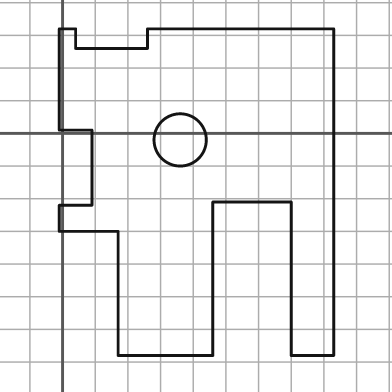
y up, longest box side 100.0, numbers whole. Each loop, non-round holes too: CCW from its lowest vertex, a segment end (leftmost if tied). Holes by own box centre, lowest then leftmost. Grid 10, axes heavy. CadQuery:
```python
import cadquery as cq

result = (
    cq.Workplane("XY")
    .moveTo(17.0, -68.0)
    .lineTo(46.0, -68.0)
    .lineTo(46.0, -21.0)
    .lineTo(70.0, -21.0)
    .lineTo(70.0, -68.0)
    .lineTo(83.0, -68.0)
    .lineTo(83.0, 32.0)
    .lineTo(26.0, 32.0)
    .lineTo(26.0, 26.0)
    .lineTo(4.0, 26.0)
    .lineTo(4.0, 32.0)
    .lineTo(-1.0, 32.0)
    .lineTo(-1.0, 1.0)
    .lineTo(9.0, 1.0)
    .lineTo(9.0, -22.0)
    .lineTo(-1.0, -22.0)
    .lineTo(-1.0, -30.0)
    .lineTo(17.0, -30.0)
    .close()
    .moveTo(36.0, -2.0)
    .circle(8.0)
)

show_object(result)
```